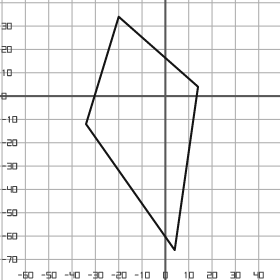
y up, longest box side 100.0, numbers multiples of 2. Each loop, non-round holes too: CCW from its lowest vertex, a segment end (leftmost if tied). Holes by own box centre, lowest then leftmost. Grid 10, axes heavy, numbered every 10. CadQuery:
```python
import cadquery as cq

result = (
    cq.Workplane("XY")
    .moveTo(4.0, -66.0)
    .lineTo(14.0, 4.0)
    .lineTo(-20.0, 34.0)
    .lineTo(-34.0, -12.0)
    .close()
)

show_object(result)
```